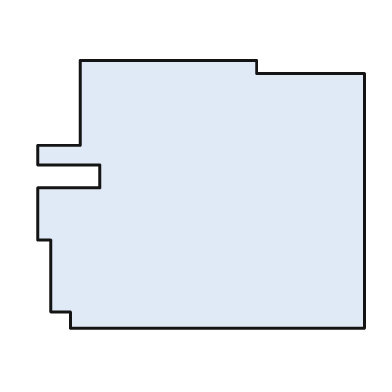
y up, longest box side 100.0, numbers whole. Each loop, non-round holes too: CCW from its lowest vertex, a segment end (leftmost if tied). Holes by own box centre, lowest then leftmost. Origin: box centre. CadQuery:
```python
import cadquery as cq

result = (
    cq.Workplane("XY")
    .moveTo(-40.0, -41.0)
    .lineTo(50.0, -41.0)
    .lineTo(50.0, 37.0)
    .lineTo(17.0, 37.0)
    .lineTo(17.0, 41.0)
    .lineTo(-37.0, 41.0)
    .lineTo(-37.0, 15.0)
    .lineTo(-50.0, 15.0)
    .lineTo(-50.0, 9.0)
    .lineTo(-31.0, 9.0)
    .lineTo(-31.0, 2.0)
    .lineTo(-50.0, 2.0)
    .lineTo(-50.0, -14.0)
    .lineTo(-46.0, -14.0)
    .lineTo(-46.0, -36.0)
    .lineTo(-40.0, -36.0)
    .close()
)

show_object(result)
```